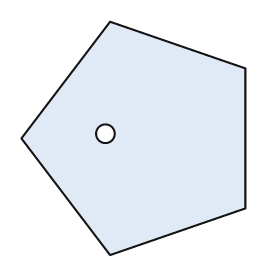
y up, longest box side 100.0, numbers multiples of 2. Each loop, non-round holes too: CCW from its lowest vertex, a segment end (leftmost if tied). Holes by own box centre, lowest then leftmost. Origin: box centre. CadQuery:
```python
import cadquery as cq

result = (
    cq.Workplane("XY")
    .moveTo(-10.0, -50.0)
    .lineTo(48.0, -30.0)
    .lineTo(48.0, 30.0)
    .lineTo(-10.0, 50.0)
    .lineTo(-48.0, 0.0)
    .close()
    .moveTo(-12.0, 2.0)
    .circle(4.0)
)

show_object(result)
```